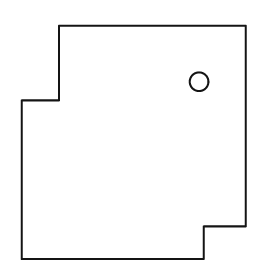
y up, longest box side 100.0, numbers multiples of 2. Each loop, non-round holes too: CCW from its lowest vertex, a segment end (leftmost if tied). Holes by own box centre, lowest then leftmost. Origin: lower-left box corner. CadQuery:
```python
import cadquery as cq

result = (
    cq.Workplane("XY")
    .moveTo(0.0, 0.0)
    .lineTo(78.0, 0.0)
    .lineTo(78.0, 14.0)
    .lineTo(96.0, 14.0)
    .lineTo(96.0, 100.0)
    .lineTo(16.0, 100.0)
    .lineTo(16.0, 68.0)
    .lineTo(0.0, 68.0)
    .close()
    .moveTo(76.0, 76.0)
    .circle(4.0)
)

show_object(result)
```